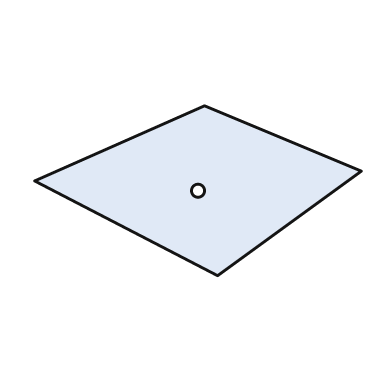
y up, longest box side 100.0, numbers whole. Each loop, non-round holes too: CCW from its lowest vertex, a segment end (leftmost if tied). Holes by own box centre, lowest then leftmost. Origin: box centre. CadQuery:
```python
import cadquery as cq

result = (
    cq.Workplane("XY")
    .moveTo(6.0, -26.0)
    .lineTo(50.0, 6.0)
    .lineTo(2.0, 26.0)
    .lineTo(-50.0, 3.0)
    .close()
    .moveTo(0.0, 0.0)
    .circle(2.0)
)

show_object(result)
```